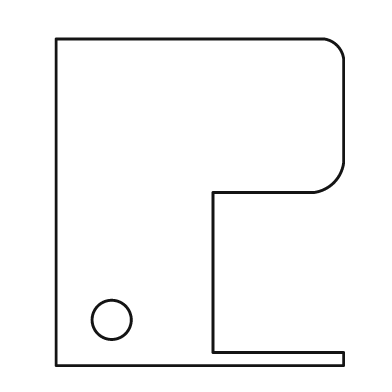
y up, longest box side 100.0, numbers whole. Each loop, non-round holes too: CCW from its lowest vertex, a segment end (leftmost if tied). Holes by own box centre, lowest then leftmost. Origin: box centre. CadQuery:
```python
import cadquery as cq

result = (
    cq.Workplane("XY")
    .moveTo(-44.0, -50.0)
    .lineTo(44.0, -50.0)
    .lineTo(44.0, -46.0)
    .lineTo(4.0, -46.0)
    .lineTo(4.0, 3.0)
    .lineTo(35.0, 3.0)
    .threePointArc((41.0, 6.0), (44.0, 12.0))
    .lineTo(44.0, 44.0)
    .threePointArc((42.0, 48.0), (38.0, 50.0))
    .lineTo(-44.0, 50.0)
    .close()
    .moveTo(-27.0, -36.0)
    .circle(6.0)
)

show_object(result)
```